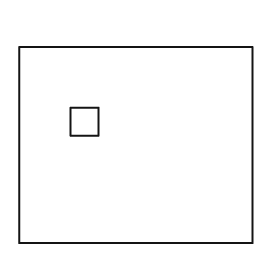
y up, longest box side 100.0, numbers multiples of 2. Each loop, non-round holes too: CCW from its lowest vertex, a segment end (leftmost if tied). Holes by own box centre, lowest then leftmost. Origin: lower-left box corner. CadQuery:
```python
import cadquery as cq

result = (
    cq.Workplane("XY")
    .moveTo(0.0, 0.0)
    .lineTo(100.0, 0.0)
    .lineTo(100.0, 84.0)
    .lineTo(0.0, 84.0)
    .close()
    .moveTo(22.0, 46.0)
    .lineTo(34.0, 46.0)
    .lineTo(34.0, 58.0)
    .lineTo(22.0, 58.0)
    .close()
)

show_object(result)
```